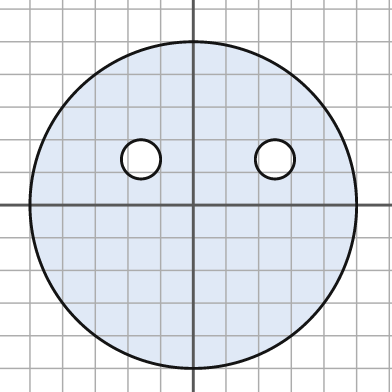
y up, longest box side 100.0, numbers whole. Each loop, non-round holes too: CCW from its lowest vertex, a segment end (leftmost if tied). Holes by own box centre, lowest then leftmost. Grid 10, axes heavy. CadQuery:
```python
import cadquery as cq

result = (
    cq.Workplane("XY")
    .moveTo(0.0, 0.0)
    .circle(50.0)
    .moveTo(-16.0, 14.0)
    .circle(6.0)
    .moveTo(25.0, 14.0)
    .circle(6.0)
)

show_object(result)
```